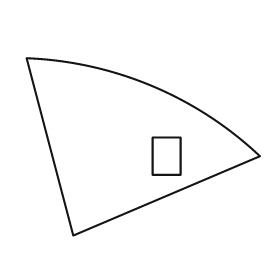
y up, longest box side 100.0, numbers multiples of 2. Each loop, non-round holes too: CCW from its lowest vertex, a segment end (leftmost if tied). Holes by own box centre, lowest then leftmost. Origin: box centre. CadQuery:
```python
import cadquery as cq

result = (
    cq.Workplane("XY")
    .moveTo(-30.0, -38.0)
    .lineTo(50.0, -4.0)
    .threePointArc((4.0, 26.0), (-50.0, 38.0))
    .close()
    .moveTo(4.0, -12.0)
    .lineTo(16.0, -12.0)
    .lineTo(16.0, 4.0)
    .lineTo(4.0, 4.0)
    .close()
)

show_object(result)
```